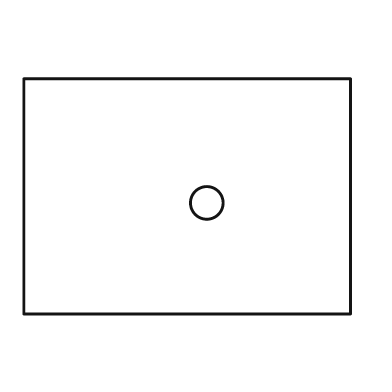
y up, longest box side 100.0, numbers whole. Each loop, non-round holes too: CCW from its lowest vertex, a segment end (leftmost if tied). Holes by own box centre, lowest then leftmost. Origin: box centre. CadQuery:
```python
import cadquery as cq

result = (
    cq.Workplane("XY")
    .moveTo(-50.0, -36.0)
    .lineTo(50.0, -36.0)
    .lineTo(50.0, 36.0)
    .lineTo(-50.0, 36.0)
    .close()
    .moveTo(6.0, -2.0)
    .circle(5.0)
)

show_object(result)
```